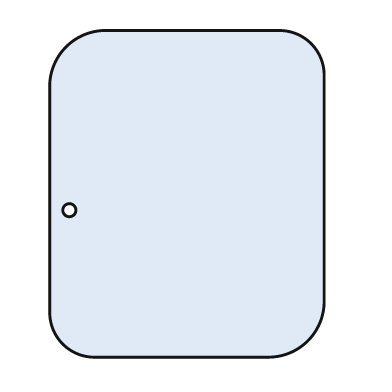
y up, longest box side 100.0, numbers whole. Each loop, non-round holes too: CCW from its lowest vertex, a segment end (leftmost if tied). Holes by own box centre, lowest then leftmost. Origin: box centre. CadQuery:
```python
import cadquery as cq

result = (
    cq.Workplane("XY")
    .moveTo(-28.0, -50.0)
    .lineTo(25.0, -50.0)
    .threePointArc((37.0, -45.0), (42.0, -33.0))
    .lineTo(42.0, 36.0)
    .threePointArc((38.0, 46.0), (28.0, 50.0))
    .lineTo(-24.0, 50.0)
    .threePointArc((-37.0, 45.0), (-42.0, 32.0))
    .lineTo(-42.0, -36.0)
    .threePointArc((-38.0, -46.0), (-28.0, -50.0))
    .close()
    .moveTo(-36.0, -5.0)
    .circle(2.0)
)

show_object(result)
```